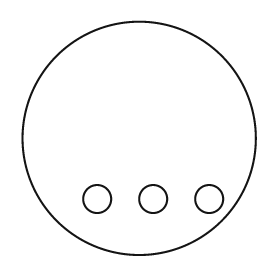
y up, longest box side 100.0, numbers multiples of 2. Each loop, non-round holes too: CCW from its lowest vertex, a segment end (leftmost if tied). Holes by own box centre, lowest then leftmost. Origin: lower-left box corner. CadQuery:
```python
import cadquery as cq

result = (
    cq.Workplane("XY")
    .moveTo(50.0, 50.0)
    .circle(50.0)
    .moveTo(32.0, 24.0)
    .circle(6.0)
    .moveTo(56.0, 24.0)
    .circle(6.0)
    .moveTo(80.0, 24.0)
    .circle(6.0)
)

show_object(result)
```